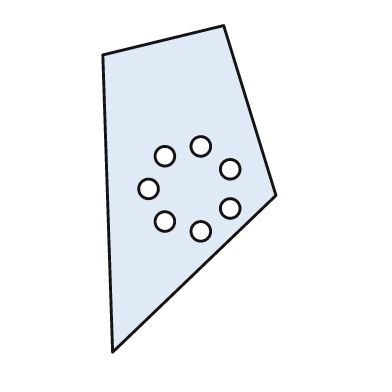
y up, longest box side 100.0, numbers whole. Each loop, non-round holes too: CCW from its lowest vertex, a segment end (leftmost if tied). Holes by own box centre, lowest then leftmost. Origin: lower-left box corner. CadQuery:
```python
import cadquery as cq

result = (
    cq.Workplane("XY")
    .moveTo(3.0, 0.0)
    .lineTo(53.0, 48.0)
    .lineTo(37.0, 100.0)
    .lineTo(0.0, 91.0)
    .close()
    .moveTo(30.0, 37.0)
    .circle(3.0)
    .moveTo(19.0, 40.0)
    .circle(3.0)
    .moveTo(39.0, 44.0)
    .circle(3.0)
    .moveTo(14.0, 50.0)
    .circle(3.0)
    .moveTo(39.0, 56.0)
    .circle(3.0)
    .moveTo(19.0, 60.0)
    .circle(3.0)
    .moveTo(30.0, 63.0)
    .circle(3.0)
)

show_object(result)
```